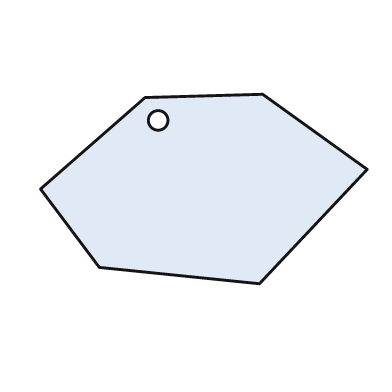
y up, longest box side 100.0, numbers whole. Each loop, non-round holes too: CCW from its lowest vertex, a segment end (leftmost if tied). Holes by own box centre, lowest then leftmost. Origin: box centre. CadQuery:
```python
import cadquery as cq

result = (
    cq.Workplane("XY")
    .moveTo(17.0, -29.0)
    .lineTo(50.0, 6.0)
    .lineTo(18.0, 29.0)
    .lineTo(-18.0, 28.0)
    .lineTo(-50.0, 0.0)
    .lineTo(-32.0, -24.0)
    .close()
    .moveTo(-14.0, 21.0)
    .circle(3.0)
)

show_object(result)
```